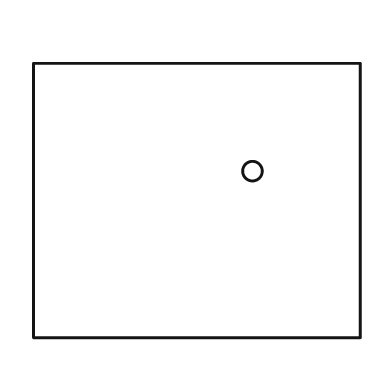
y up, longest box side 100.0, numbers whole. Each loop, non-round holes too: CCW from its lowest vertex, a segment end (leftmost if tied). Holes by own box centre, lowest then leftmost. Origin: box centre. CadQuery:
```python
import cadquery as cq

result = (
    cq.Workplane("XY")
    .moveTo(-50.0, -42.0)
    .lineTo(50.0, -42.0)
    .lineTo(50.0, 42.0)
    .lineTo(-50.0, 42.0)
    .close()
    .moveTo(17.0, 9.0)
    .circle(3.0)
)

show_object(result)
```